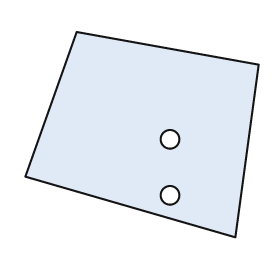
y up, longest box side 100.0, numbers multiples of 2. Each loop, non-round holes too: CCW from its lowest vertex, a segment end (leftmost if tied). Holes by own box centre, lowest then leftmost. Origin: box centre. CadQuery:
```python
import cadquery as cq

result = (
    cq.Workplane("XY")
    .moveTo(40.0, -44.0)
    .lineTo(50.0, 30.0)
    .lineTo(-28.0, 44.0)
    .lineTo(-50.0, -18.0)
    .close()
    .moveTo(12.0, -26.0)
    .circle(4.0)
    .moveTo(12.0, -2.0)
    .circle(4.0)
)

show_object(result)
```